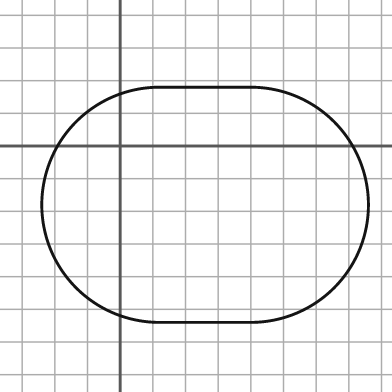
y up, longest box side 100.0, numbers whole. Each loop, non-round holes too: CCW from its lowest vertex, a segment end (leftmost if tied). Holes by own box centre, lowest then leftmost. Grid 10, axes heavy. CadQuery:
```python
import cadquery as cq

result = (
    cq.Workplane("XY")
    .moveTo(12.0, -54.0)
    .lineTo(40.0, -54.0)
    .threePointArc((76.0, -18.0), (40.0, 18.0))
    .lineTo(12.0, 18.0)
    .threePointArc((-24.0, -18.0), (12.0, -54.0))
    .close()
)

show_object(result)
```